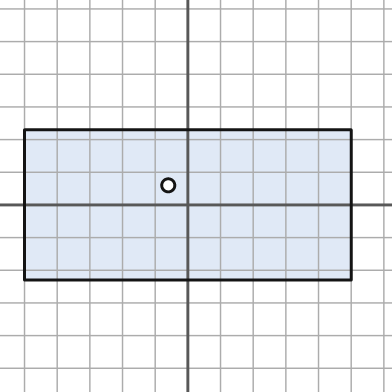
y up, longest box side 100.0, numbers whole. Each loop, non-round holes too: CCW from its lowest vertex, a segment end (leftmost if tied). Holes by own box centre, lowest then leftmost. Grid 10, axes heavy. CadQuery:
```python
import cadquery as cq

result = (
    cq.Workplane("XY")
    .moveTo(-50.0, -23.0)
    .lineTo(50.0, -23.0)
    .lineTo(50.0, 23.0)
    .lineTo(-50.0, 23.0)
    .close()
    .moveTo(-6.0, 6.0)
    .circle(2.0)
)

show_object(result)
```